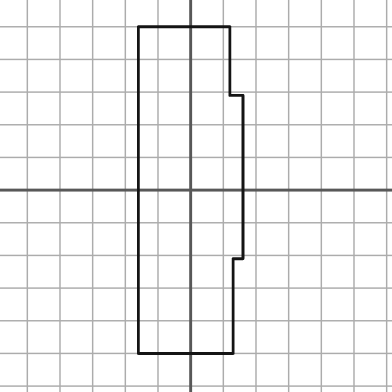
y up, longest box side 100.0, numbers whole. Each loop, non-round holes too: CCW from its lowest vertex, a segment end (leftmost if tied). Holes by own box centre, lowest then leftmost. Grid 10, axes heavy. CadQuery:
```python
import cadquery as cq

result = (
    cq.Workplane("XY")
    .moveTo(-16.0, -50.0)
    .lineTo(13.0, -50.0)
    .lineTo(13.0, -21.0)
    .lineTo(16.0, -21.0)
    .lineTo(16.0, 29.0)
    .lineTo(12.0, 29.0)
    .lineTo(12.0, 50.0)
    .lineTo(-16.0, 50.0)
    .close()
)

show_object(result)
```